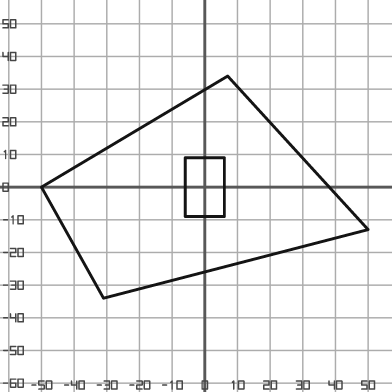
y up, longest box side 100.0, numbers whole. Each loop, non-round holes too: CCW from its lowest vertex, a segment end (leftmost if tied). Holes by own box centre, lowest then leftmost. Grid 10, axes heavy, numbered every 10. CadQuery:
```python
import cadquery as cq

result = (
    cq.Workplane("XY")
    .moveTo(-31.0, -34.0)
    .lineTo(50.0, -13.0)
    .lineTo(7.0, 34.0)
    .lineTo(-50.0, 0.0)
    .close()
    .moveTo(-6.0, -9.0)
    .lineTo(6.0, -9.0)
    .lineTo(6.0, 9.0)
    .lineTo(-6.0, 9.0)
    .close()
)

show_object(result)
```